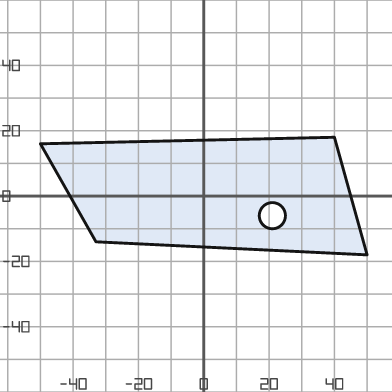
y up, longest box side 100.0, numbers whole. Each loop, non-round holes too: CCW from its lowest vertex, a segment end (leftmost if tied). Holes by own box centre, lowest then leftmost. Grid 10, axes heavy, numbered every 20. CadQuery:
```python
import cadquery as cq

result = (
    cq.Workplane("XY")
    .moveTo(50.0, -18.0)
    .lineTo(40.0, 18.0)
    .lineTo(-50.0, 16.0)
    .lineTo(-33.0, -14.0)
    .close()
    .moveTo(21.0, -6.0)
    .circle(4.0)
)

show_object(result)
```